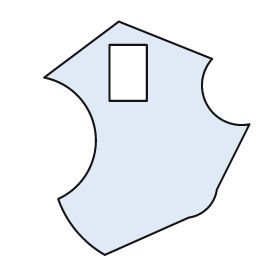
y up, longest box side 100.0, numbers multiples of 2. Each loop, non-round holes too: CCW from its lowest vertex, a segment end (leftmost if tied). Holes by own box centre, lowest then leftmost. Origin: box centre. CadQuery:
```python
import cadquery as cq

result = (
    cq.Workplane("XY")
    .moveTo(-18.0, -50.0)
    .lineTo(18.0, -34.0)
    .threePointArc((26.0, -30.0), (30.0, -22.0))
    .lineTo(44.0, 6.0)
    .threePointArc((26.0, 14.0), (28.0, 34.0))
    .lineTo(-12.0, 50.0)
    .lineTo(-44.0, 26.0)
    .threePointArc((-22.0, 2.0), (-38.0, -26.0))
    .threePointArc((-30.0, -40.0), (-18.0, -50.0))
    .close()
    .moveTo(-16.0, 16.0)
    .lineTo(0.0, 16.0)
    .lineTo(0.0, 40.0)
    .lineTo(-16.0, 40.0)
    .close()
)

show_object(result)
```